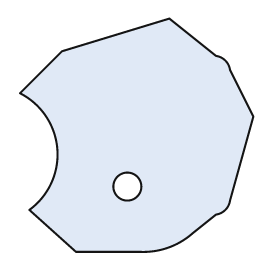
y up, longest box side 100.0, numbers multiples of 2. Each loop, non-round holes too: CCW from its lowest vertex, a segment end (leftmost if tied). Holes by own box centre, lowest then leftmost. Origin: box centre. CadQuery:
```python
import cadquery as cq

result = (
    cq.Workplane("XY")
    .moveTo(-26.0, -50.0)
    .lineTo(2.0, -50.0)
    .threePointArc((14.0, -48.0), (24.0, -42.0))
    .lineTo(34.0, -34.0)
    .threePointArc((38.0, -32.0), (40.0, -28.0))
    .lineTo(50.0, 8.0)
    .lineTo(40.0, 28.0)
    .threePointArc((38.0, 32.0), (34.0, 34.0))
    .lineTo(14.0, 50.0)
    .lineTo(-32.0, 36.0)
    .lineTo(-50.0, 18.0)
    .threePointArc((-34.0, -6.0), (-46.0, -32.0))
    .close()
    .moveTo(-4.0, -22.0)
    .circle(6.0)
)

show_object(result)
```